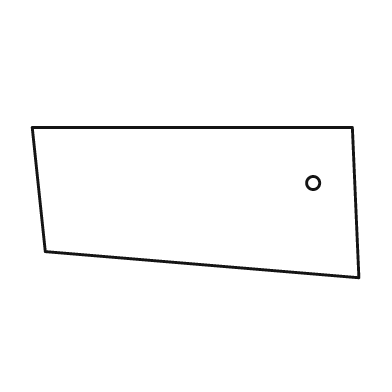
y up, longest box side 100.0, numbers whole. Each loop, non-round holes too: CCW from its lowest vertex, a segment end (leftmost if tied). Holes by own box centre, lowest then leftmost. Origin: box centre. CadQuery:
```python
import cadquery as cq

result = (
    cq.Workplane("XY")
    .moveTo(50.0, -23.0)
    .lineTo(48.0, 23.0)
    .lineTo(-50.0, 23.0)
    .lineTo(-46.0, -15.0)
    .close()
    .moveTo(36.0, 6.0)
    .circle(2.0)
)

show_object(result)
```